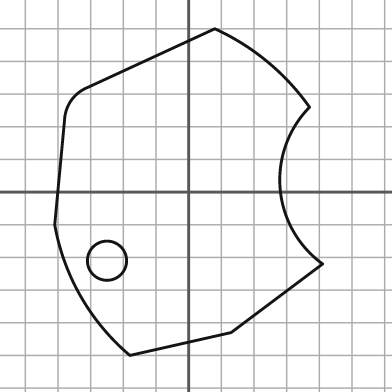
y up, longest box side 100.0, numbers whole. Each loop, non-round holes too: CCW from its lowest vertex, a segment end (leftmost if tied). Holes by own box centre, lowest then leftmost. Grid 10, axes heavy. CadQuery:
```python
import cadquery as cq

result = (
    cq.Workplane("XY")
    .moveTo(-18.0, -50.0)
    .lineTo(13.0, -43.0)
    .lineTo(41.0, -22.0)
    .threePointArc((28.0, 1.0), (37.0, 26.0))
    .threePointArc((24.0, 40.0), (8.0, 50.0))
    .lineTo(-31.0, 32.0)
    .threePointArc((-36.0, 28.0), (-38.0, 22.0))
    .lineTo(-41.0, -10.0)
    .threePointArc((-33.0, -32.0), (-18.0, -50.0))
    .close()
    .moveTo(-25.0, -21.0)
    .circle(6.0)
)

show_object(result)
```